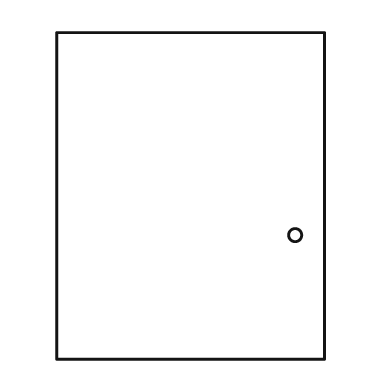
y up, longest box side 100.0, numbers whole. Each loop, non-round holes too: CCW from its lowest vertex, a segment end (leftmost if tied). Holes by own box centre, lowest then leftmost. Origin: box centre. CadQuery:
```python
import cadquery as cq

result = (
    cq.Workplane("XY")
    .moveTo(-41.0, -50.0)
    .lineTo(41.0, -50.0)
    .lineTo(41.0, 50.0)
    .lineTo(-41.0, 50.0)
    .close()
    .moveTo(32.0, -12.0)
    .circle(2.0)
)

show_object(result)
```